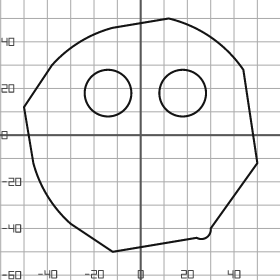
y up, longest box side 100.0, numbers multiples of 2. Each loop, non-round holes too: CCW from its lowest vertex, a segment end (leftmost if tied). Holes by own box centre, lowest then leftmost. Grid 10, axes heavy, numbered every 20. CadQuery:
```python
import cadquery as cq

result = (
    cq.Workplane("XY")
    .moveTo(-12.0, -50.0)
    .lineTo(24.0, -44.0)
    .threePointArc((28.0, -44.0), (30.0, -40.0))
    .lineTo(50.0, -12.0)
    .lineTo(44.0, 28.0)
    .threePointArc((30.0, 42.0), (12.0, 50.0))
    .lineTo(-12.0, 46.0)
    .threePointArc((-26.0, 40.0), (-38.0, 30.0))
    .lineTo(-50.0, 12.0)
    .lineTo(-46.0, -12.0)
    .threePointArc((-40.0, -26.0), (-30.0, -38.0))
    .close()
    .moveTo(-14.0, 18.0)
    .circle(10.0)
    .moveTo(18.0, 18.0)
    .circle(10.0)
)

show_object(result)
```